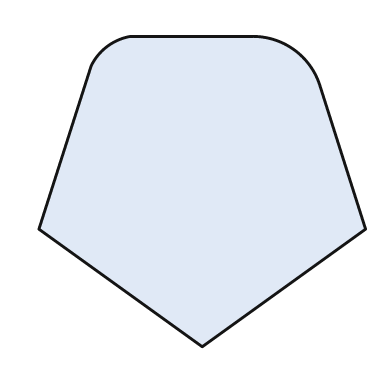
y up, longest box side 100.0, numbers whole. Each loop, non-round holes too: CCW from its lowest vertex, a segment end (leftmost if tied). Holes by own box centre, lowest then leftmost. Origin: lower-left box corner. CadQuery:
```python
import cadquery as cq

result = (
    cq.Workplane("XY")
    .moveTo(50.0, 0.0)
    .lineTo(100.0, 36.0)
    .lineTo(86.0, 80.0)
    .threePointArc((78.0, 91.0), (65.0, 95.0))
    .lineTo(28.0, 95.0)
    .threePointArc((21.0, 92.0), (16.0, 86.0))
    .lineTo(0.0, 36.0)
    .close()
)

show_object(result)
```